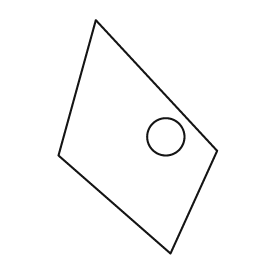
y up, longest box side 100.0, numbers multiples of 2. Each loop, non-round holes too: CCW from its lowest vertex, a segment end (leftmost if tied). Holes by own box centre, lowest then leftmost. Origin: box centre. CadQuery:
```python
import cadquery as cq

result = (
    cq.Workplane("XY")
    .moveTo(14.0, -50.0)
    .lineTo(34.0, -6.0)
    .lineTo(-18.0, 50.0)
    .lineTo(-34.0, -8.0)
    .close()
    .moveTo(12.0, 0.0)
    .circle(8.0)
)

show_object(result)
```